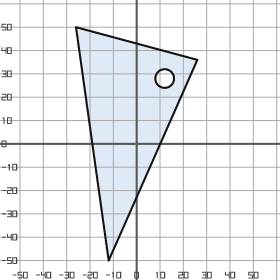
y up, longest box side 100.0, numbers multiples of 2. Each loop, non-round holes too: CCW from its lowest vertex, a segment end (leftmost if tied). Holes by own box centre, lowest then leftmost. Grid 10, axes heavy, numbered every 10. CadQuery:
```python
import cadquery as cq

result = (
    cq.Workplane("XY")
    .moveTo(-12.0, -50.0)
    .lineTo(26.0, 36.0)
    .lineTo(-26.0, 50.0)
    .close()
    .moveTo(12.0, 28.0)
    .circle(4.0)
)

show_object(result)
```